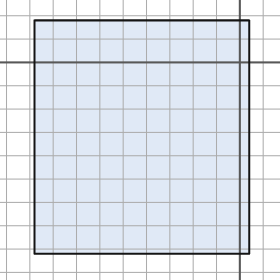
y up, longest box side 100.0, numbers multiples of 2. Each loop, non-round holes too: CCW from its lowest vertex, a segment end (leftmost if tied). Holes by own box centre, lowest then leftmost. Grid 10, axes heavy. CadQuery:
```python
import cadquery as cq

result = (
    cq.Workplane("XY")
    .moveTo(-88.0, -82.0)
    .lineTo(4.0, -82.0)
    .lineTo(4.0, 18.0)
    .lineTo(-88.0, 18.0)
    .close()
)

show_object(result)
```